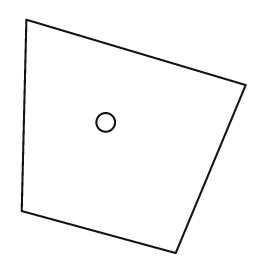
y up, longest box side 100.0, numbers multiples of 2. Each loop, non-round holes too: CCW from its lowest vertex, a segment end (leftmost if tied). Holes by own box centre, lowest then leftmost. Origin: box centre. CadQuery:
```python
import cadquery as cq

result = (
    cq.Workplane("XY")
    .moveTo(18.0, -50.0)
    .lineTo(48.0, 22.0)
    .lineTo(-46.0, 50.0)
    .lineTo(-48.0, -32.0)
    .close()
    .moveTo(-12.0, 6.0)
    .circle(4.0)
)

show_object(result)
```